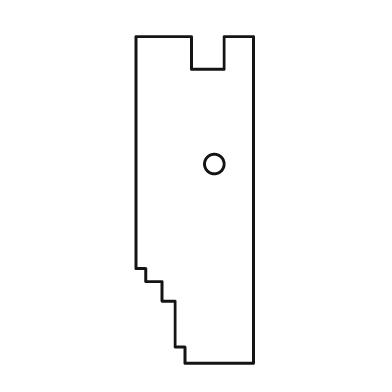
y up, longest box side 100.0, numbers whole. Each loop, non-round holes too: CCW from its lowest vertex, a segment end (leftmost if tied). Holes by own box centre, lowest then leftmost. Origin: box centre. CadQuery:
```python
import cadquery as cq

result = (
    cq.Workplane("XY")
    .moveTo(-3.0, -50.0)
    .lineTo(18.0, -50.0)
    .lineTo(18.0, 50.0)
    .lineTo(9.0, 50.0)
    .lineTo(9.0, 40.0)
    .lineTo(-1.0, 40.0)
    .lineTo(-1.0, 50.0)
    .lineTo(-18.0, 50.0)
    .lineTo(-18.0, -21.0)
    .lineTo(-15.0, -21.0)
    .lineTo(-15.0, -25.0)
    .lineTo(-10.0, -25.0)
    .lineTo(-10.0, -31.0)
    .lineTo(-6.0, -31.0)
    .lineTo(-6.0, -45.0)
    .lineTo(-3.0, -45.0)
    .close()
    .moveTo(6.0, 11.0)
    .circle(3.0)
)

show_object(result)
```